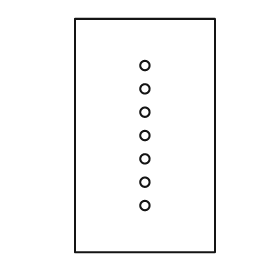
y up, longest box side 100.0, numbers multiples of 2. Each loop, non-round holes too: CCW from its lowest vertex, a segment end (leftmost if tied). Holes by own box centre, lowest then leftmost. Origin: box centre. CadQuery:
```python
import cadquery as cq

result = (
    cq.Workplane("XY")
    .moveTo(-30.0, -50.0)
    .lineTo(30.0, -50.0)
    .lineTo(30.0, 50.0)
    .lineTo(-30.0, 50.0)
    .close()
    .moveTo(0.0, -30.0)
    .circle(2.0)
    .moveTo(0.0, -20.0)
    .circle(2.0)
    .moveTo(0.0, -10.0)
    .circle(2.0)
    .moveTo(0.0, 0.0)
    .circle(2.0)
    .moveTo(0.0, 10.0)
    .circle(2.0)
    .moveTo(0.0, 20.0)
    .circle(2.0)
    .moveTo(0.0, 30.0)
    .circle(2.0)
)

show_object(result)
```